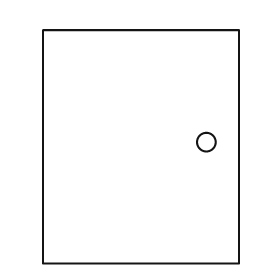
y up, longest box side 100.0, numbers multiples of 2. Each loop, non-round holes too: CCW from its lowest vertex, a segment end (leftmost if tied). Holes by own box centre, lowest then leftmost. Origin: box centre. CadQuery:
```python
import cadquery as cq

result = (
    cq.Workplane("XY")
    .moveTo(-42.0, -50.0)
    .lineTo(42.0, -50.0)
    .lineTo(42.0, 50.0)
    .lineTo(-42.0, 50.0)
    .close()
    .moveTo(28.0, 2.0)
    .circle(4.0)
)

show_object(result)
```